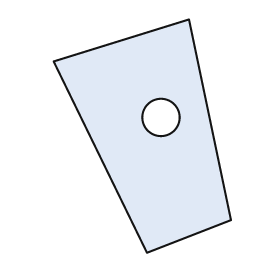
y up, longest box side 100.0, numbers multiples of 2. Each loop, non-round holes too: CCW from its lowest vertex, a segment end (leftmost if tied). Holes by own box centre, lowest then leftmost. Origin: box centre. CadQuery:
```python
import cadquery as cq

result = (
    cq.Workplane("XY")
    .moveTo(2.0, -50.0)
    .lineTo(38.0, -36.0)
    .lineTo(20.0, 50.0)
    .lineTo(-38.0, 32.0)
    .close()
    .moveTo(8.0, 8.0)
    .circle(8.0)
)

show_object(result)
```